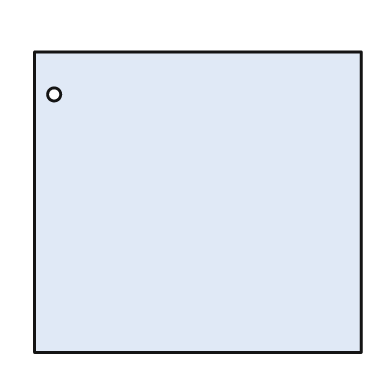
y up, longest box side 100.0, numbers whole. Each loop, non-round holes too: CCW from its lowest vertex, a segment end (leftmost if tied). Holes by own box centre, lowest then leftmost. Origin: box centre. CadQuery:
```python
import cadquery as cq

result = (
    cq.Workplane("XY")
    .moveTo(-50.0, -46.0)
    .lineTo(50.0, -46.0)
    .lineTo(50.0, 46.0)
    .lineTo(-50.0, 46.0)
    .close()
    .moveTo(-44.0, 33.0)
    .circle(2.0)
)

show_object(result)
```